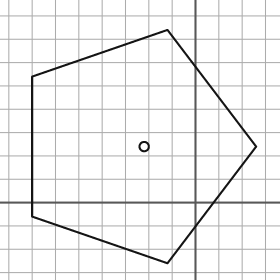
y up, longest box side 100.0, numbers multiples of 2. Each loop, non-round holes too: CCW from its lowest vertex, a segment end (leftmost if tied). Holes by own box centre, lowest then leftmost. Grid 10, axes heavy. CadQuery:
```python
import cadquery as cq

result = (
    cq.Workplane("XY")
    .moveTo(-12.0, -26.0)
    .lineTo(26.0, 24.0)
    .lineTo(-12.0, 74.0)
    .lineTo(-70.0, 54.0)
    .lineTo(-70.0, -6.0)
    .close()
    .moveTo(-22.0, 24.0)
    .circle(2.0)
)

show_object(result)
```